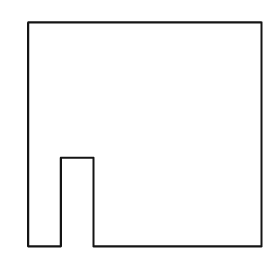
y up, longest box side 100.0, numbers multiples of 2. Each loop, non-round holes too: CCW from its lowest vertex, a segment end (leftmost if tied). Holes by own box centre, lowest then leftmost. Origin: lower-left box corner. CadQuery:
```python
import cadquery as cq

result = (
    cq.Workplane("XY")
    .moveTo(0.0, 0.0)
    .lineTo(14.0, 0.0)
    .lineTo(14.0, 38.0)
    .lineTo(28.0, 38.0)
    .lineTo(28.0, 0.0)
    .lineTo(100.0, 0.0)
    .lineTo(100.0, 96.0)
    .lineTo(0.0, 96.0)
    .close()
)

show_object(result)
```